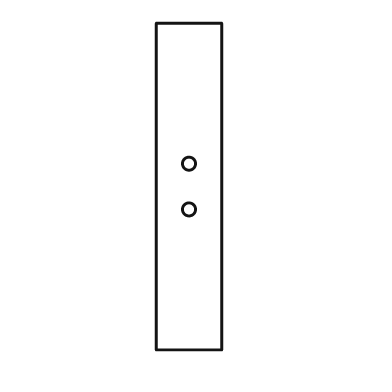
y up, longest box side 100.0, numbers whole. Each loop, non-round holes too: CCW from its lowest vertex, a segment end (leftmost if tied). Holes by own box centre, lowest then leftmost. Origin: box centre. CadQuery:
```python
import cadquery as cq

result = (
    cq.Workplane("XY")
    .moveTo(-10.0, -50.0)
    .lineTo(10.0, -50.0)
    .lineTo(10.0, 50.0)
    .lineTo(-10.0, 50.0)
    .close()
    .moveTo(0.0, -7.0)
    .circle(2.0)
    .moveTo(0.0, 7.0)
    .circle(2.0)
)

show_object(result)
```